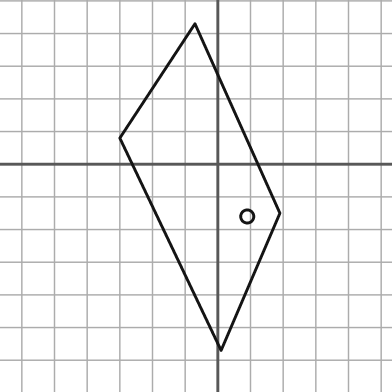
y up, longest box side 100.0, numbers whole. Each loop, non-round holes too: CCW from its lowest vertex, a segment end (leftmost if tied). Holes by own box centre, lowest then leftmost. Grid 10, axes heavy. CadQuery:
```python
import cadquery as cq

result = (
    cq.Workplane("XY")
    .moveTo(1.0, -57.0)
    .lineTo(19.0, -15.0)
    .lineTo(-7.0, 43.0)
    .lineTo(-30.0, 8.0)
    .close()
    .moveTo(9.0, -16.0)
    .circle(2.0)
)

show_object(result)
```